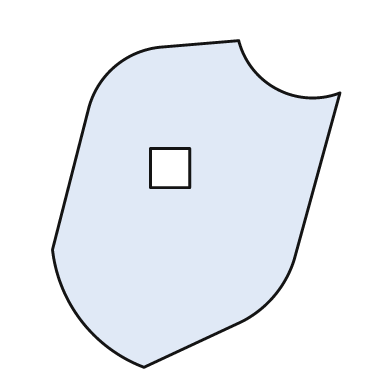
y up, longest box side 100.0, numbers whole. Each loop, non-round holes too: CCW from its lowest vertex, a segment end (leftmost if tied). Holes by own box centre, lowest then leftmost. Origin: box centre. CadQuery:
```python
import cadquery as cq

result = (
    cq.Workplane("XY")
    .moveTo(-16.0, -50.0)
    .lineTo(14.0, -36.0)
    .threePointArc((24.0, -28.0), (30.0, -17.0))
    .lineTo(44.0, 34.0)
    .threePointArc((25.0, 35.0), (13.0, 50.0))
    .lineTo(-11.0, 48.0)
    .threePointArc((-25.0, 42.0), (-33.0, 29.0))
    .lineTo(-44.0, -14.0)
    .threePointArc((-35.0, -36.0), (-16.0, -50.0))
    .close()
    .moveTo(-14.0, 5.0)
    .lineTo(-2.0, 5.0)
    .lineTo(-2.0, 17.0)
    .lineTo(-14.0, 17.0)
    .close()
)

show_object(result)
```